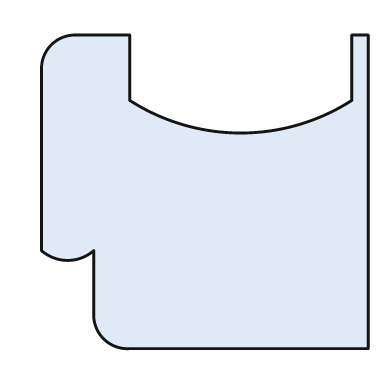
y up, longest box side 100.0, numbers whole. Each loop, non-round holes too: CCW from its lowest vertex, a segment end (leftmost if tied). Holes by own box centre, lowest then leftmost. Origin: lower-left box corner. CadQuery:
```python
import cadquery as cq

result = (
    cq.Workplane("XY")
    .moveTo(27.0, 0.0)
    .lineTo(100.0, 0.0)
    .lineTo(100.0, 96.0)
    .lineTo(95.0, 96.0)
    .lineTo(95.0, 76.0)
    .threePointArc((61.0, 66.0), (27.0, 76.0))
    .lineTo(27.0, 96.0)
    .lineTo(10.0, 96.0)
    .threePointArc((3.0, 93.0), (0.0, 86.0))
    .lineTo(0.0, 30.0)
    .threePointArc((8.0, 27.0), (16.0, 30.0))
    .lineTo(16.0, 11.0)
    .threePointArc((19.0, 3.0), (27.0, 0.0))
    .close()
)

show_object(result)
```